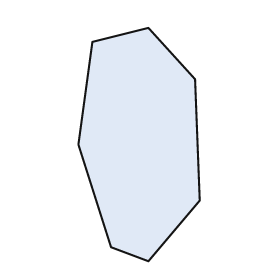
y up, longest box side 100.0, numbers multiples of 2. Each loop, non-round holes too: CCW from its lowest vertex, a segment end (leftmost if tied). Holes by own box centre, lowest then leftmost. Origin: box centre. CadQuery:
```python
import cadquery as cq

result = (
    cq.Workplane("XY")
    .moveTo(4.0, -50.0)
    .lineTo(26.0, -24.0)
    .lineTo(24.0, 28.0)
    .lineTo(4.0, 50.0)
    .lineTo(-20.0, 44.0)
    .lineTo(-26.0, 0.0)
    .lineTo(-12.0, -44.0)
    .close()
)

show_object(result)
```